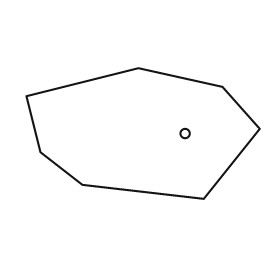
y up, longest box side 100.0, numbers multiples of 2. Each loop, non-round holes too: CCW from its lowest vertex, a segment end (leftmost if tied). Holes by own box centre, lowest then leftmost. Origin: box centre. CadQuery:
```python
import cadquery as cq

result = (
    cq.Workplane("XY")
    .moveTo(26.0, -28.0)
    .lineTo(50.0, 2.0)
    .lineTo(34.0, 20.0)
    .lineTo(-2.0, 28.0)
    .lineTo(-50.0, 16.0)
    .lineTo(-44.0, -8.0)
    .lineTo(-26.0, -22.0)
    .close()
    .moveTo(18.0, 0.0)
    .circle(2.0)
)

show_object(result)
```